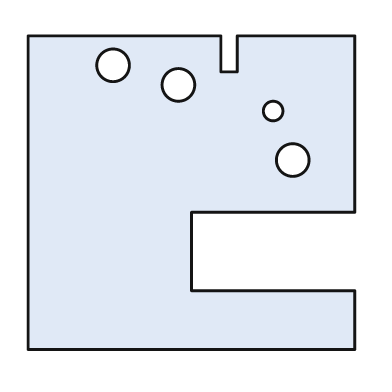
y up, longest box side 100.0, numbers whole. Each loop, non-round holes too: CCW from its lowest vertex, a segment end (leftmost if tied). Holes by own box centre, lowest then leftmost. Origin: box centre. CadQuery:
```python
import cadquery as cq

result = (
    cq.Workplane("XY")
    .moveTo(-50.0, -48.0)
    .lineTo(50.0, -48.0)
    .lineTo(50.0, -30.0)
    .lineTo(0.0, -30.0)
    .lineTo(0.0, -6.0)
    .lineTo(50.0, -6.0)
    .lineTo(50.0, 48.0)
    .lineTo(14.0, 48.0)
    .lineTo(14.0, 37.0)
    .lineTo(9.0, 37.0)
    .lineTo(9.0, 48.0)
    .lineTo(-50.0, 48.0)
    .close()
    .moveTo(31.0, 10.0)
    .circle(5.0)
    .moveTo(25.0, 25.0)
    .circle(3.0)
    .moveTo(-4.0, 33.0)
    .circle(5.0)
    .moveTo(-24.0, 39.0)
    .circle(5.0)
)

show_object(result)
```